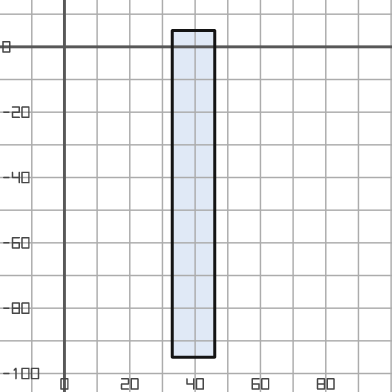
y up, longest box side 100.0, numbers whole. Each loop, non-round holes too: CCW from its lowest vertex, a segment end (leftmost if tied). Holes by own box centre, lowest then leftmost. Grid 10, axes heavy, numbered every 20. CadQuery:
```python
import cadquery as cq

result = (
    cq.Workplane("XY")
    .moveTo(33.0, -95.0)
    .lineTo(46.0, -95.0)
    .lineTo(46.0, 5.0)
    .lineTo(33.0, 5.0)
    .close()
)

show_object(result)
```